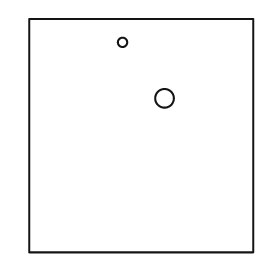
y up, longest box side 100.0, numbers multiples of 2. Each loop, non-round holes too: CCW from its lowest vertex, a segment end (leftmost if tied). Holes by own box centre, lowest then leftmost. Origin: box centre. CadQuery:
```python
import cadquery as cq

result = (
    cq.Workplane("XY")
    .moveTo(-48.0, -50.0)
    .lineTo(48.0, -50.0)
    .lineTo(48.0, 50.0)
    .lineTo(-48.0, 50.0)
    .close()
    .moveTo(10.0, 16.0)
    .circle(4.0)
    .moveTo(-8.0, 40.0)
    .circle(2.0)
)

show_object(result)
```